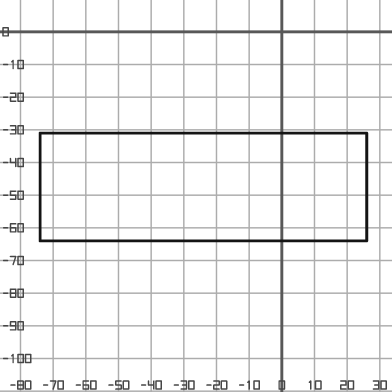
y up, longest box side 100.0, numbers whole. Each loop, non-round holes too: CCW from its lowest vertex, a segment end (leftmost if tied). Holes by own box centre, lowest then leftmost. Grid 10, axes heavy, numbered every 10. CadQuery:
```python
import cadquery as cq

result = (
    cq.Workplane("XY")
    .moveTo(-74.0, -64.0)
    .lineTo(26.0, -64.0)
    .lineTo(26.0, -31.0)
    .lineTo(-74.0, -31.0)
    .close()
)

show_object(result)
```